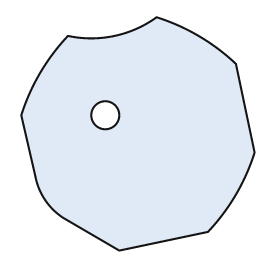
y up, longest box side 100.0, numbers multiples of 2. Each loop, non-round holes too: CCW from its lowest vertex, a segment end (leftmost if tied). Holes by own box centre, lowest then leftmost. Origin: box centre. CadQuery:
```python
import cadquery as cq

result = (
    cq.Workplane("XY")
    .moveTo(-8.0, -50.0)
    .lineTo(30.0, -42.0)
    .threePointArc((42.0, -26.0), (50.0, -8.0))
    .lineTo(42.0, 30.0)
    .threePointArc((26.0, 42.0), (8.0, 50.0))
    .threePointArc((-10.0, 42.0), (-30.0, 42.0))
    .threePointArc((-42.0, 26.0), (-50.0, 8.0))
    .lineTo(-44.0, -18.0)
    .threePointArc((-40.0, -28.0), (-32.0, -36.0))
    .close()
    .moveTo(-14.0, 8.0)
    .circle(6.0)
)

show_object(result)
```